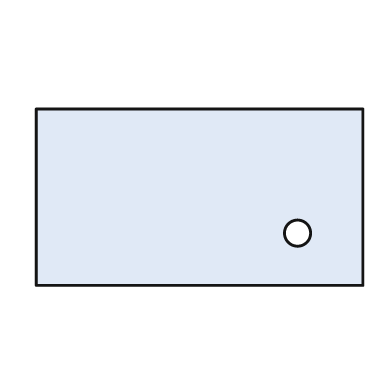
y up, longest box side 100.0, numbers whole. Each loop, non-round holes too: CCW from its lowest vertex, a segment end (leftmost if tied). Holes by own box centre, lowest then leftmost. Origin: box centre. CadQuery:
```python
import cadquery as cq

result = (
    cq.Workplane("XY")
    .moveTo(-50.0, -27.0)
    .lineTo(50.0, -27.0)
    .lineTo(50.0, 27.0)
    .lineTo(-50.0, 27.0)
    .close()
    .moveTo(30.0, -11.0)
    .circle(4.0)
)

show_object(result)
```